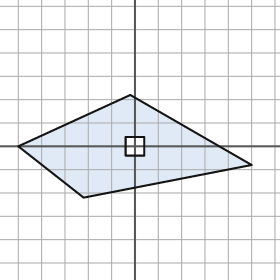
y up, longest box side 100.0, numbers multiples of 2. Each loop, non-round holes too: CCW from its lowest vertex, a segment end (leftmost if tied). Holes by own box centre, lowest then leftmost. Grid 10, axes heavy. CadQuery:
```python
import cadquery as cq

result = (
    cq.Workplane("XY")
    .moveTo(-22.0, -22.0)
    .lineTo(50.0, -8.0)
    .lineTo(-2.0, 22.0)
    .lineTo(-50.0, 0.0)
    .close()
    .moveTo(-4.0, -4.0)
    .lineTo(4.0, -4.0)
    .lineTo(4.0, 4.0)
    .lineTo(-4.0, 4.0)
    .close()
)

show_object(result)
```